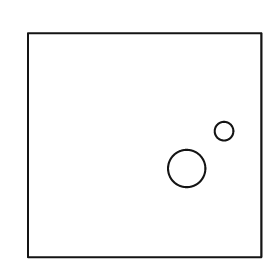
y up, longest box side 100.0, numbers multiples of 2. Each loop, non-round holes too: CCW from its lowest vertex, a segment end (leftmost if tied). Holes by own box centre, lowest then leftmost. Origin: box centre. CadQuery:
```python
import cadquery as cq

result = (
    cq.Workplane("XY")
    .moveTo(-50.0, -48.0)
    .lineTo(50.0, -48.0)
    .lineTo(50.0, 48.0)
    .lineTo(-50.0, 48.0)
    .close()
    .moveTo(18.0, -10.0)
    .circle(8.0)
    .moveTo(34.0, 6.0)
    .circle(4.0)
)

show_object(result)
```